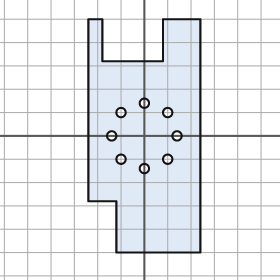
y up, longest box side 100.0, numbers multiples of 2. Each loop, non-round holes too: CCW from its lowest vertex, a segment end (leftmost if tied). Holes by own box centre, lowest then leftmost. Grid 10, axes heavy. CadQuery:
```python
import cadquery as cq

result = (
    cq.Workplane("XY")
    .moveTo(-12.0, -50.0)
    .lineTo(24.0, -50.0)
    .lineTo(24.0, 50.0)
    .lineTo(8.0, 50.0)
    .lineTo(8.0, 32.0)
    .lineTo(-18.0, 32.0)
    .lineTo(-18.0, 50.0)
    .lineTo(-24.0, 50.0)
    .lineTo(-24.0, -28.0)
    .lineTo(-12.0, -28.0)
    .close()
    .moveTo(0.0, -14.0)
    .circle(2.0)
    .moveTo(-10.0, -10.0)
    .circle(2.0)
    .moveTo(10.0, -10.0)
    .circle(2.0)
    .moveTo(-14.0, 0.0)
    .circle(2.0)
    .moveTo(14.0, 0.0)
    .circle(2.0)
    .moveTo(-10.0, 10.0)
    .circle(2.0)
    .moveTo(10.0, 10.0)
    .circle(2.0)
    .moveTo(0.0, 14.0)
    .circle(2.0)
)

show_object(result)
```